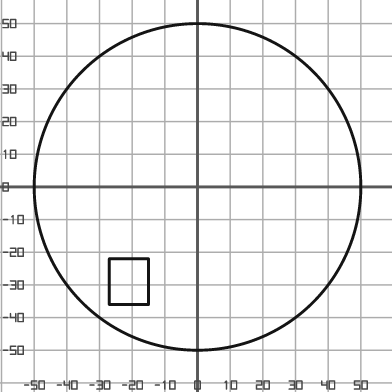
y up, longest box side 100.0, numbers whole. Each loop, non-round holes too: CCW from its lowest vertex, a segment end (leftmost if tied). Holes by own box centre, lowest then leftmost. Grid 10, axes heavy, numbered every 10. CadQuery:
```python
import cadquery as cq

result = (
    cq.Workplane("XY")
    .moveTo(0.0, 0.0)
    .circle(50.0)
    .moveTo(-27.0, -36.0)
    .lineTo(-15.0, -36.0)
    .lineTo(-15.0, -22.0)
    .lineTo(-27.0, -22.0)
    .close()
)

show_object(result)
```